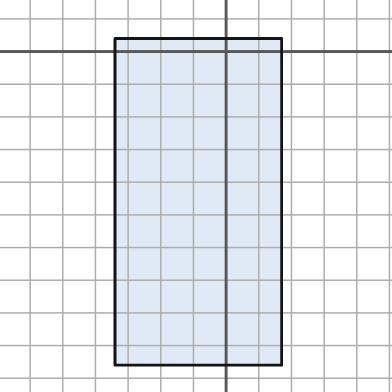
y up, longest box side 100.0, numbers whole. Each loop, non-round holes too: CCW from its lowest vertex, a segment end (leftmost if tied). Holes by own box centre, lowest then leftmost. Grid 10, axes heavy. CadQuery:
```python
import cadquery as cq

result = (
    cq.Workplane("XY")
    .moveTo(-34.0, -96.0)
    .lineTo(17.0, -96.0)
    .lineTo(17.0, 4.0)
    .lineTo(-34.0, 4.0)
    .close()
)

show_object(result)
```